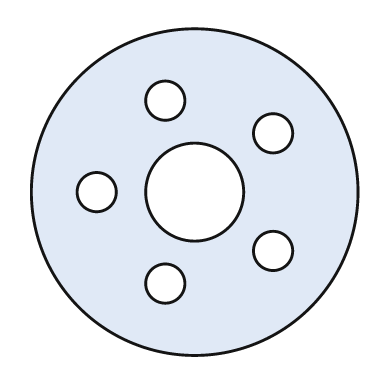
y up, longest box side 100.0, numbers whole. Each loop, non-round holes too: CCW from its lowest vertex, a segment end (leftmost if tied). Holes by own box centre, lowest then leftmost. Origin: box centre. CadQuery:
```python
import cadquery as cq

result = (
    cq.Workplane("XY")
    .moveTo(0.0, 0.0)
    .circle(50.0)
    .moveTo(-9.0, -28.0)
    .circle(6.0)
    .moveTo(24.0, -18.0)
    .circle(6.0)
    .moveTo(-30.0, 0.0)
    .circle(6.0)
    .moveTo(0.0, 0.0)
    .circle(15.0)
    .moveTo(24.0, 18.0)
    .circle(6.0)
    .moveTo(-9.0, 28.0)
    .circle(6.0)
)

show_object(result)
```